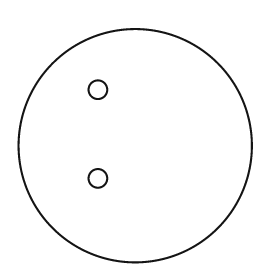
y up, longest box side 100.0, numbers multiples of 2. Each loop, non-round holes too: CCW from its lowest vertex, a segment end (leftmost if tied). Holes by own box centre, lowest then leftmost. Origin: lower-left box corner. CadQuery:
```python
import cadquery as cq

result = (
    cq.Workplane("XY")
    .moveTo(50.0, 50.0)
    .circle(50.0)
    .moveTo(34.0, 36.0)
    .circle(4.0)
    .moveTo(34.0, 74.0)
    .circle(4.0)
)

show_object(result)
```